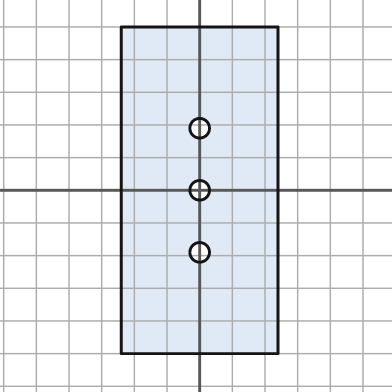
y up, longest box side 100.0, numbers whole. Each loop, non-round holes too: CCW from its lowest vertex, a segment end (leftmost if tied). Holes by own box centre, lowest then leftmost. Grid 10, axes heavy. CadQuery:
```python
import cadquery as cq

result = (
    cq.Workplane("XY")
    .moveTo(-24.0, -50.0)
    .lineTo(24.0, -50.0)
    .lineTo(24.0, 50.0)
    .lineTo(-24.0, 50.0)
    .close()
    .moveTo(0.0, -19.0)
    .circle(3.0)
    .moveTo(0.0, 0.0)
    .circle(3.0)
    .moveTo(0.0, 19.0)
    .circle(3.0)
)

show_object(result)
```